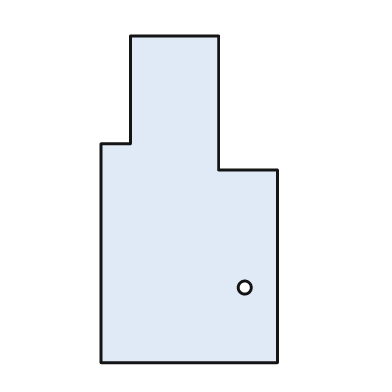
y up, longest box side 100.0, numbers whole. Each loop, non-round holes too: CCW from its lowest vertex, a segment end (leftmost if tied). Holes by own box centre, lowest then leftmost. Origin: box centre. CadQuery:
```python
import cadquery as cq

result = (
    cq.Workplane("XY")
    .moveTo(-27.0, -50.0)
    .lineTo(27.0, -50.0)
    .lineTo(27.0, 9.0)
    .lineTo(9.0, 9.0)
    .lineTo(9.0, 50.0)
    .lineTo(-18.0, 50.0)
    .lineTo(-18.0, 17.0)
    .lineTo(-27.0, 17.0)
    .close()
    .moveTo(17.0, -27.0)
    .circle(2.0)
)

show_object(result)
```